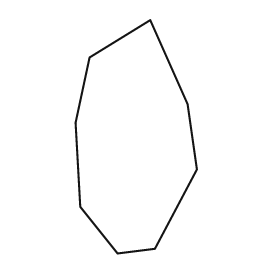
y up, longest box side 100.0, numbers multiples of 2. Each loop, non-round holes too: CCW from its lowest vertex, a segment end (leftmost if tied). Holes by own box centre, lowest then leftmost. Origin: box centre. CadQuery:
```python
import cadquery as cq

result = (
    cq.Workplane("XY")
    .moveTo(-8.0, -50.0)
    .lineTo(8.0, -48.0)
    .lineTo(26.0, -14.0)
    .lineTo(22.0, 14.0)
    .lineTo(6.0, 50.0)
    .lineTo(-20.0, 34.0)
    .lineTo(-26.0, 6.0)
    .lineTo(-24.0, -30.0)
    .close()
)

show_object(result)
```